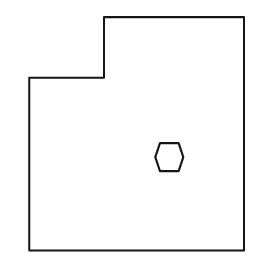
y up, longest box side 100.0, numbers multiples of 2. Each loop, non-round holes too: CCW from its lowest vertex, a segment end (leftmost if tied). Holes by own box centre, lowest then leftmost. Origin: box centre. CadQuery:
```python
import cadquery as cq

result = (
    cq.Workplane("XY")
    .moveTo(-46.0, -50.0)
    .lineTo(46.0, -50.0)
    .lineTo(46.0, 50.0)
    .lineTo(-14.0, 50.0)
    .lineTo(-14.0, 24.0)
    .lineTo(-46.0, 24.0)
    .close()
    .moveTo(10.0, -16.0)
    .lineTo(18.0, -16.0)
    .lineTo(20.0, -10.0)
    .lineTo(18.0, -4.0)
    .lineTo(10.0, -4.0)
    .lineTo(8.0, -10.0)
    .close()
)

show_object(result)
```